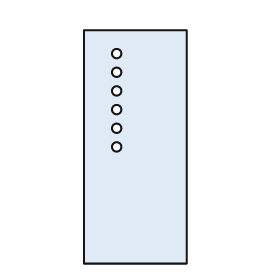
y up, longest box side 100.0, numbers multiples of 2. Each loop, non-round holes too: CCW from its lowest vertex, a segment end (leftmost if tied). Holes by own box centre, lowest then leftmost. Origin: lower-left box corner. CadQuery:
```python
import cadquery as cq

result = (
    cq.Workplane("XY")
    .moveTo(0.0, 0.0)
    .lineTo(44.0, 0.0)
    .lineTo(44.0, 100.0)
    .lineTo(0.0, 100.0)
    .close()
    .moveTo(14.0, 50.0)
    .circle(2.0)
    .moveTo(14.0, 58.0)
    .circle(2.0)
    .moveTo(14.0, 66.0)
    .circle(2.0)
    .moveTo(14.0, 74.0)
    .circle(2.0)
    .moveTo(14.0, 82.0)
    .circle(2.0)
    .moveTo(14.0, 90.0)
    .circle(2.0)
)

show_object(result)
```